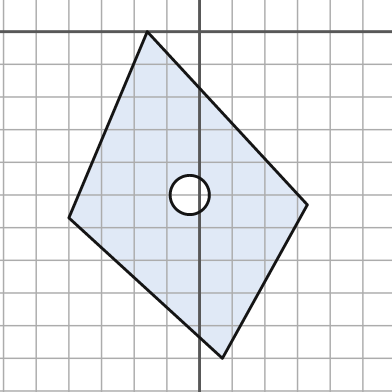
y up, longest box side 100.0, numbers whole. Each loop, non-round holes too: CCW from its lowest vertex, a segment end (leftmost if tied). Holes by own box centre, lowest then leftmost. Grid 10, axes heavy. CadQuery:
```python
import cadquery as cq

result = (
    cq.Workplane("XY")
    .moveTo(7.0, -100.0)
    .lineTo(33.0, -53.0)
    .lineTo(-16.0, 0.0)
    .lineTo(-40.0, -57.0)
    .close()
    .moveTo(-3.0, -50.0)
    .circle(6.0)
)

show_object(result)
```